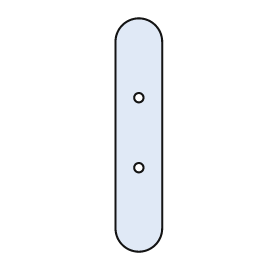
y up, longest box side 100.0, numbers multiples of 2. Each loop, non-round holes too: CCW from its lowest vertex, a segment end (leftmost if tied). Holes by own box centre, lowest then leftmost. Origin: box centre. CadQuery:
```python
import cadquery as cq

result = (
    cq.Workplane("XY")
    .moveTo(-10.0, -40.0)
    .threePointArc((0.0, -50.0), (10.0, -40.0))
    .lineTo(10.0, 40.0)
    .threePointArc((0.0, 50.0), (-10.0, 40.0))
    .close()
    .moveTo(0.0, -14.0)
    .circle(2.0)
    .moveTo(0.0, 16.0)
    .circle(2.0)
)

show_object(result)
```